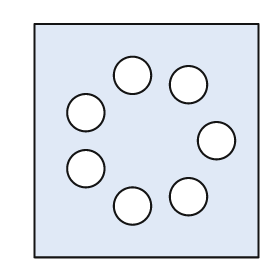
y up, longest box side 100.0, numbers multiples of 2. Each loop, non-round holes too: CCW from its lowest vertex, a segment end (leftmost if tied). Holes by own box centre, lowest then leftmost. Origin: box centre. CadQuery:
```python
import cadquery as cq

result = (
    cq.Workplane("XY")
    .moveTo(-48.0, -50.0)
    .lineTo(48.0, -50.0)
    .lineTo(48.0, 50.0)
    .lineTo(-48.0, 50.0)
    .close()
    .moveTo(-6.0, -28.0)
    .circle(8.0)
    .moveTo(18.0, -24.0)
    .circle(8.0)
    .moveTo(-26.0, -12.0)
    .circle(8.0)
    .moveTo(30.0, 0.0)
    .circle(8.0)
    .moveTo(-26.0, 12.0)
    .circle(8.0)
    .moveTo(18.0, 24.0)
    .circle(8.0)
    .moveTo(-6.0, 28.0)
    .circle(8.0)
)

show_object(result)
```